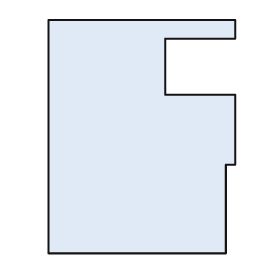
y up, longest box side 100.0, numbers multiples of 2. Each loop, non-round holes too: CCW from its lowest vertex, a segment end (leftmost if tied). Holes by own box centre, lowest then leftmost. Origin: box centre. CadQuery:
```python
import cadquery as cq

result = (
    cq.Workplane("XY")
    .moveTo(-40.0, -50.0)
    .lineTo(36.0, -50.0)
    .lineTo(36.0, -12.0)
    .lineTo(40.0, -12.0)
    .lineTo(40.0, 18.0)
    .lineTo(10.0, 18.0)
    .lineTo(10.0, 42.0)
    .lineTo(40.0, 42.0)
    .lineTo(40.0, 50.0)
    .lineTo(-40.0, 50.0)
    .close()
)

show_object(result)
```